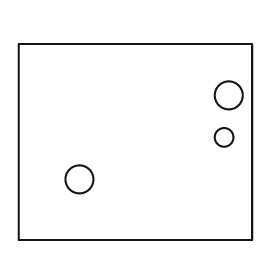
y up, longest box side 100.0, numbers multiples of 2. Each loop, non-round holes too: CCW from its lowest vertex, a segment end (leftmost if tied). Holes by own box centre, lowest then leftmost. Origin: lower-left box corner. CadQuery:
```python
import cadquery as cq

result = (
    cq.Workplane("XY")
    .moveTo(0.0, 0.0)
    .lineTo(100.0, 0.0)
    .lineTo(100.0, 84.0)
    .lineTo(0.0, 84.0)
    .close()
    .moveTo(26.0, 26.0)
    .circle(6.0)
    .moveTo(88.0, 44.0)
    .circle(4.0)
    .moveTo(90.0, 62.0)
    .circle(6.0)
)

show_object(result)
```